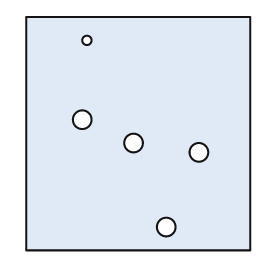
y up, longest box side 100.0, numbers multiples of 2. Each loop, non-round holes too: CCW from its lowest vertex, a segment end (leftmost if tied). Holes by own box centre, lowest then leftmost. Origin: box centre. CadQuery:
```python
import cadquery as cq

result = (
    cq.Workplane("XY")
    .moveTo(-48.0, -50.0)
    .lineTo(48.0, -50.0)
    .lineTo(48.0, 50.0)
    .lineTo(-48.0, 50.0)
    .close()
    .moveTo(12.0, -40.0)
    .circle(4.0)
    .moveTo(26.0, -8.0)
    .circle(4.0)
    .moveTo(-2.0, -4.0)
    .circle(4.0)
    .moveTo(-24.0, 6.0)
    .circle(4.0)
    .moveTo(-22.0, 40.0)
    .circle(2.0)
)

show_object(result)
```